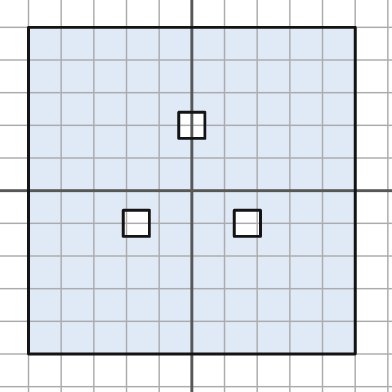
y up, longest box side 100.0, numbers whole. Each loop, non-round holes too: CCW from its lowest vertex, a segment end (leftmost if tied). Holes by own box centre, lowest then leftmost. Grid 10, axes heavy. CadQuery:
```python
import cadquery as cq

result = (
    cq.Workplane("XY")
    .moveTo(-50.0, -50.0)
    .lineTo(50.0, -50.0)
    .lineTo(50.0, 50.0)
    .lineTo(-50.0, 50.0)
    .close()
    .moveTo(-21.0, -14.0)
    .lineTo(-13.0, -14.0)
    .lineTo(-13.0, -6.0)
    .lineTo(-21.0, -6.0)
    .close()
    .moveTo(13.0, -14.0)
    .lineTo(21.0, -14.0)
    .lineTo(21.0, -6.0)
    .lineTo(13.0, -6.0)
    .close()
    .moveTo(-4.0, 16.0)
    .lineTo(4.0, 16.0)
    .lineTo(4.0, 24.0)
    .lineTo(-4.0, 24.0)
    .close()
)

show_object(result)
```